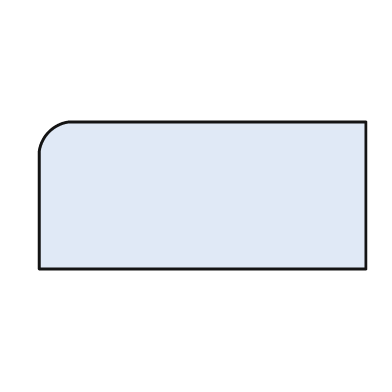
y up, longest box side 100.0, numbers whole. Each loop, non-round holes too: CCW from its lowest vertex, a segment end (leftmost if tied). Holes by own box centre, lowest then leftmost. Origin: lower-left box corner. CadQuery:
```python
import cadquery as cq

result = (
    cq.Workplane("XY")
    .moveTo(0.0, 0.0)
    .lineTo(100.0, 0.0)
    .lineTo(100.0, 45.0)
    .lineTo(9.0, 45.0)
    .threePointArc((3.0, 42.0), (0.0, 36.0))
    .close()
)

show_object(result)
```